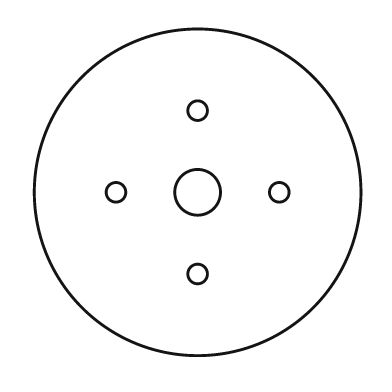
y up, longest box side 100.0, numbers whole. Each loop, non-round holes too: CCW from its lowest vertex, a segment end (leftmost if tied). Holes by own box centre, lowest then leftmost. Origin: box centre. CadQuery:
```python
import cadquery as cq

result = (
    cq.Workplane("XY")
    .moveTo(0.0, 0.0)
    .circle(50.0)
    .moveTo(0.0, -25.0)
    .circle(3.0)
    .moveTo(-25.0, 0.0)
    .circle(3.0)
    .moveTo(0.0, 0.0)
    .circle(7.0)
    .moveTo(25.0, 0.0)
    .circle(3.0)
    .moveTo(0.0, 25.0)
    .circle(3.0)
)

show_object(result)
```